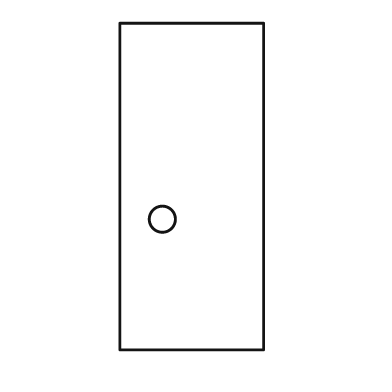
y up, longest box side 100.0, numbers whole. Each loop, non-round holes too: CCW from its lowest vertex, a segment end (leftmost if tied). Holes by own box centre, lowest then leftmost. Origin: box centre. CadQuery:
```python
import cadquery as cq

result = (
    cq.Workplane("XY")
    .moveTo(-22.0, -50.0)
    .lineTo(22.0, -50.0)
    .lineTo(22.0, 50.0)
    .lineTo(-22.0, 50.0)
    .close()
    .moveTo(-9.0, -10.0)
    .circle(4.0)
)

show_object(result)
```